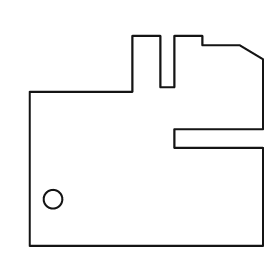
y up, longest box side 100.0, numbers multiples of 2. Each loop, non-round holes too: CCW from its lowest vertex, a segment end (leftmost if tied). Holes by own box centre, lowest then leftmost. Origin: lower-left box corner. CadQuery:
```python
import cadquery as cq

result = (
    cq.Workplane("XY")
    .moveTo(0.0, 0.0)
    .lineTo(100.0, 0.0)
    .lineTo(100.0, 42.0)
    .lineTo(62.0, 42.0)
    .lineTo(62.0, 50.0)
    .lineTo(100.0, 50.0)
    .lineTo(100.0, 80.0)
    .lineTo(90.0, 86.0)
    .lineTo(74.0, 86.0)
    .lineTo(74.0, 90.0)
    .lineTo(62.0, 90.0)
    .lineTo(62.0, 68.0)
    .lineTo(56.0, 68.0)
    .lineTo(56.0, 90.0)
    .lineTo(44.0, 90.0)
    .lineTo(44.0, 66.0)
    .lineTo(0.0, 66.0)
    .close()
    .moveTo(10.0, 20.0)
    .circle(4.0)
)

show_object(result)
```